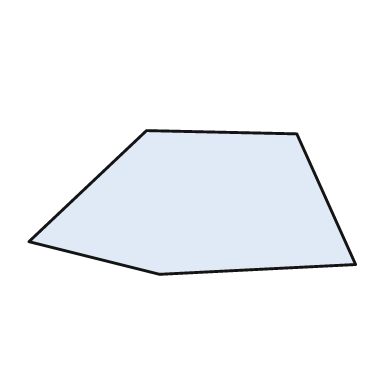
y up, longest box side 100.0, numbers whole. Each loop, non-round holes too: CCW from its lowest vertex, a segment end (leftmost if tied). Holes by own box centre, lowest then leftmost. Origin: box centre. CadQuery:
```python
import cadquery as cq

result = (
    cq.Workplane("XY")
    .moveTo(-10.0, -22.0)
    .lineTo(50.0, -19.0)
    .lineTo(32.0, 21.0)
    .lineTo(-14.0, 22.0)
    .lineTo(-50.0, -12.0)
    .close()
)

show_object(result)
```